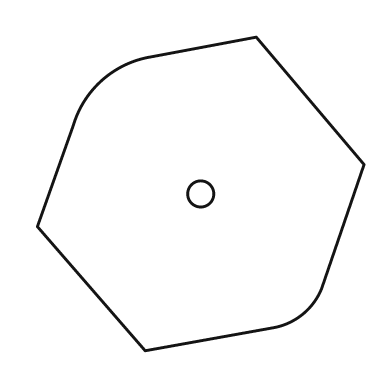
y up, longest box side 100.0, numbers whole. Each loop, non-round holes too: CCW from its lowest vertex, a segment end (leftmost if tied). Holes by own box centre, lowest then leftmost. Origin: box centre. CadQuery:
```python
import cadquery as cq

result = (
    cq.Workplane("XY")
    .moveTo(-17.0, -48.0)
    .lineTo(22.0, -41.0)
    .threePointArc((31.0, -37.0), (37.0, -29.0))
    .lineTo(50.0, 9.0)
    .lineTo(17.0, 48.0)
    .lineTo(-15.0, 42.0)
    .threePointArc((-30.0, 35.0), (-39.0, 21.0))
    .lineTo(-50.0, -10.0)
    .close()
    .moveTo(0.0, 0.0)
    .circle(4.0)
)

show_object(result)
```